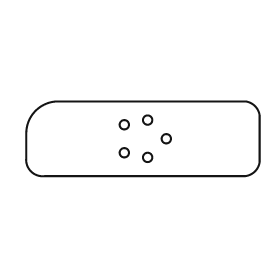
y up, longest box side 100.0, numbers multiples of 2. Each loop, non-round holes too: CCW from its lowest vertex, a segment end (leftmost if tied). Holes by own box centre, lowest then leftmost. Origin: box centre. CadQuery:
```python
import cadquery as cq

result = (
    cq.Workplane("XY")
    .moveTo(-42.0, -16.0)
    .lineTo(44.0, -16.0)
    .threePointArc((48.0, -14.0), (50.0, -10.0))
    .lineTo(50.0, 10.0)
    .threePointArc((48.0, 14.0), (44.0, 16.0))
    .lineTo(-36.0, 16.0)
    .threePointArc((-46.0, 12.0), (-50.0, 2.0))
    .lineTo(-50.0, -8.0)
    .threePointArc((-48.0, -14.0), (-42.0, -16.0))
    .close()
    .moveTo(2.0, -8.0)
    .circle(2.0)
    .moveTo(-8.0, -6.0)
    .circle(2.0)
    .moveTo(10.0, 0.0)
    .circle(2.0)
    .moveTo(-8.0, 6.0)
    .circle(2.0)
    .moveTo(2.0, 8.0)
    .circle(2.0)
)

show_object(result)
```